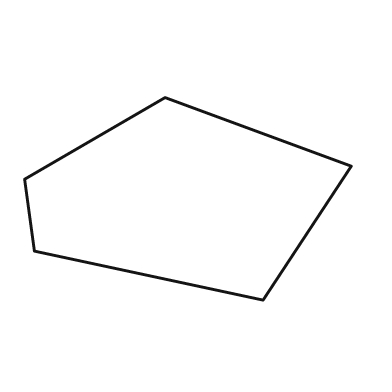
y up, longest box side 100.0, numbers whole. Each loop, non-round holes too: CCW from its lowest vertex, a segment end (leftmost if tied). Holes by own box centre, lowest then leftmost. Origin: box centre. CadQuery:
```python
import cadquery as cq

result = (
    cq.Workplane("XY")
    .moveTo(23.0, -31.0)
    .lineTo(50.0, 10.0)
    .lineTo(-7.0, 31.0)
    .lineTo(-50.0, 6.0)
    .lineTo(-47.0, -16.0)
    .close()
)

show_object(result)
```